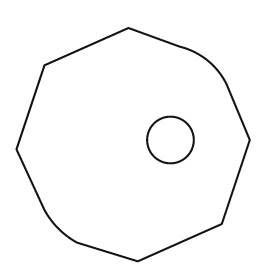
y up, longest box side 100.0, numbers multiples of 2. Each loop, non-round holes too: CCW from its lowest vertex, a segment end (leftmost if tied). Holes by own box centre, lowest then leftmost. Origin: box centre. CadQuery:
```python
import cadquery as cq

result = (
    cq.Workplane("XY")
    .moveTo(2.0, -50.0)
    .lineTo(38.0, -34.0)
    .lineTo(50.0, 2.0)
    .lineTo(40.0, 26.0)
    .threePointArc((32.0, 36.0), (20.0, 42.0))
    .lineTo(-2.0, 50.0)
    .lineTo(-38.0, 34.0)
    .lineTo(-50.0, -2.0)
    .lineTo(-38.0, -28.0)
    .threePointArc((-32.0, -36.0), (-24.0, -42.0))
    .close()
    .moveTo(16.0, 2.0)
    .circle(10.0)
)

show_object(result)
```